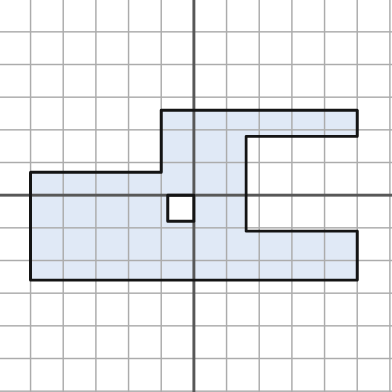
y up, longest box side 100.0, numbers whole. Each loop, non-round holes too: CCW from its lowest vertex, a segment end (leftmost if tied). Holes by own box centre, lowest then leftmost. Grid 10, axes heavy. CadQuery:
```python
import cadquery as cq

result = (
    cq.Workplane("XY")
    .moveTo(-50.0, -26.0)
    .lineTo(50.0, -26.0)
    .lineTo(50.0, -11.0)
    .lineTo(16.0, -11.0)
    .lineTo(16.0, 18.0)
    .lineTo(50.0, 18.0)
    .lineTo(50.0, 26.0)
    .lineTo(-10.0, 26.0)
    .lineTo(-10.0, 7.0)
    .lineTo(-50.0, 7.0)
    .close()
    .moveTo(-8.0, -8.0)
    .lineTo(0.0, -8.0)
    .lineTo(0.0, 0.0)
    .lineTo(-8.0, 0.0)
    .close()
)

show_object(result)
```